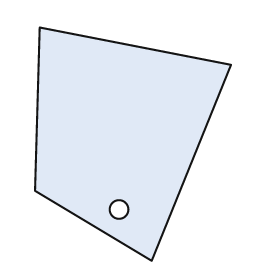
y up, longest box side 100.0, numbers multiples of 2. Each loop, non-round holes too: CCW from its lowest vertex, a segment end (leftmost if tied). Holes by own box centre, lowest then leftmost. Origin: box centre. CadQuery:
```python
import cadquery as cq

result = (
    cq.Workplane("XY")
    .moveTo(8.0, -50.0)
    .lineTo(42.0, 34.0)
    .lineTo(-40.0, 50.0)
    .lineTo(-42.0, -20.0)
    .close()
    .moveTo(-6.0, -28.0)
    .circle(4.0)
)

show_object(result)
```